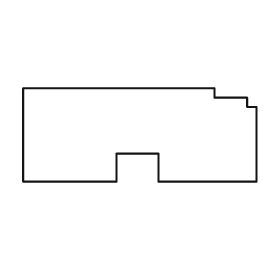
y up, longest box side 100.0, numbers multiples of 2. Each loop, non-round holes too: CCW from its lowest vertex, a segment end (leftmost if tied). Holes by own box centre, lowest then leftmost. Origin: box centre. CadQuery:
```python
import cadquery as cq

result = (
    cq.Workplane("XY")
    .moveTo(-50.0, -20.0)
    .lineTo(-10.0, -20.0)
    .lineTo(-10.0, -8.0)
    .lineTo(8.0, -8.0)
    .lineTo(8.0, -20.0)
    .lineTo(50.0, -20.0)
    .lineTo(50.0, 12.0)
    .lineTo(46.0, 12.0)
    .lineTo(46.0, 16.0)
    .lineTo(32.0, 16.0)
    .lineTo(32.0, 20.0)
    .lineTo(-50.0, 20.0)
    .close()
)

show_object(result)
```